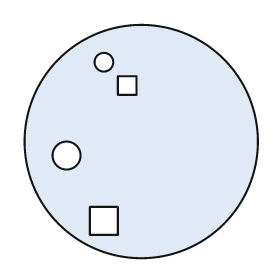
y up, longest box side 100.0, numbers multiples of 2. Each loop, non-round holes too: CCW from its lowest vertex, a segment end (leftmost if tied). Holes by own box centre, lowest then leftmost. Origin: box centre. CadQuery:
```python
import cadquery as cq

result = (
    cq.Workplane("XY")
    .moveTo(0.0, 0.0)
    .circle(50.0)
    .moveTo(-22.0, -40.0)
    .lineTo(-10.0, -40.0)
    .lineTo(-10.0, -28.0)
    .lineTo(-22.0, -28.0)
    .close()
    .moveTo(-32.0, -6.0)
    .circle(6.0)
    .moveTo(-10.0, 20.0)
    .lineTo(-2.0, 20.0)
    .lineTo(-2.0, 28.0)
    .lineTo(-10.0, 28.0)
    .close()
    .moveTo(-16.0, 34.0)
    .circle(4.0)
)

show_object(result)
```